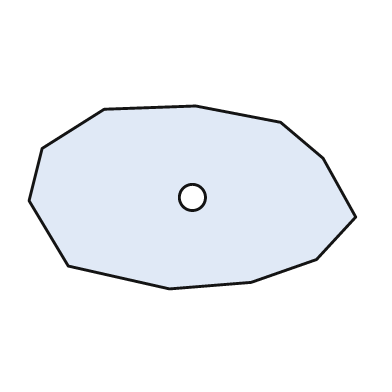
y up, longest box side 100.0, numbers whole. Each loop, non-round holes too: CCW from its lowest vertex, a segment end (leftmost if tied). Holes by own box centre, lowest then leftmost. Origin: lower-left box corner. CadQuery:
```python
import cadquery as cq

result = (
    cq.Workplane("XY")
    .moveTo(43.0, 0.0)
    .lineTo(68.0, 2.0)
    .lineTo(88.0, 9.0)
    .lineTo(100.0, 22.0)
    .lineTo(90.0, 40.0)
    .lineTo(77.0, 51.0)
    .lineTo(51.0, 56.0)
    .lineTo(23.0, 55.0)
    .lineTo(4.0, 43.0)
    .lineTo(0.0, 27.0)
    .lineTo(12.0, 7.0)
    .close()
    .moveTo(50.0, 28.0)
    .circle(4.0)
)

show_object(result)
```